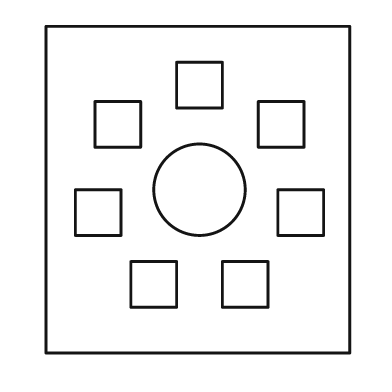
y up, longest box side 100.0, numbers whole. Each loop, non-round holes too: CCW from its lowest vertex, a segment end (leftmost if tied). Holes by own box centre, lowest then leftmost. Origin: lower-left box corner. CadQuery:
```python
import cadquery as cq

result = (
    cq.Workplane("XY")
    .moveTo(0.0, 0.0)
    .lineTo(93.0, 0.0)
    .lineTo(93.0, 100.0)
    .lineTo(0.0, 100.0)
    .close()
    .moveTo(26.0, 14.0)
    .lineTo(40.0, 14.0)
    .lineTo(40.0, 28.0)
    .lineTo(26.0, 28.0)
    .close()
    .moveTo(54.0, 14.0)
    .lineTo(68.0, 14.0)
    .lineTo(68.0, 28.0)
    .lineTo(54.0, 28.0)
    .close()
    .moveTo(9.0, 36.0)
    .lineTo(23.0, 36.0)
    .lineTo(23.0, 50.0)
    .lineTo(9.0, 50.0)
    .close()
    .moveTo(71.0, 36.0)
    .lineTo(85.0, 36.0)
    .lineTo(85.0, 50.0)
    .lineTo(71.0, 50.0)
    .close()
    .moveTo(47.0, 50.0)
    .circle(14.0)
    .moveTo(15.0, 63.0)
    .lineTo(29.0, 63.0)
    .lineTo(29.0, 77.0)
    .lineTo(15.0, 77.0)
    .close()
    .moveTo(65.0, 63.0)
    .lineTo(79.0, 63.0)
    .lineTo(79.0, 77.0)
    .lineTo(65.0, 77.0)
    .close()
    .moveTo(40.0, 75.0)
    .lineTo(54.0, 75.0)
    .lineTo(54.0, 89.0)
    .lineTo(40.0, 89.0)
    .close()
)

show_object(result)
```